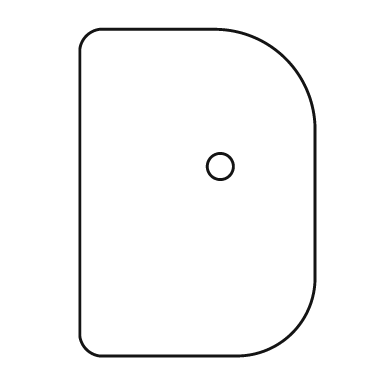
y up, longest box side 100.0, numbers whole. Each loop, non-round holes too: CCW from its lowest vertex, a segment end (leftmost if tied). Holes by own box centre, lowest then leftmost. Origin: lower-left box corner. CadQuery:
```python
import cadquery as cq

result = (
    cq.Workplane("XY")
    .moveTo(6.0, 0.0)
    .lineTo(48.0, 0.0)
    .threePointArc((65.0, 7.0), (72.0, 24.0))
    .lineTo(72.0, 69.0)
    .threePointArc((63.0, 91.0), (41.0, 100.0))
    .lineTo(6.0, 100.0)
    .threePointArc((2.0, 98.0), (0.0, 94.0))
    .lineTo(0.0, 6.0)
    .threePointArc((2.0, 2.0), (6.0, 0.0))
    .close()
    .moveTo(43.0, 58.0)
    .circle(4.0)
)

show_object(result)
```